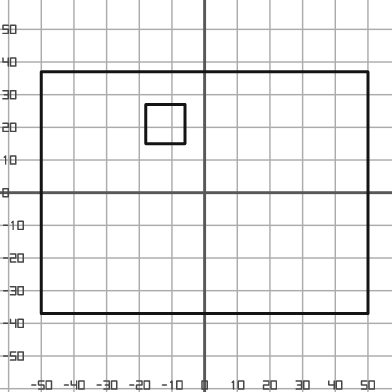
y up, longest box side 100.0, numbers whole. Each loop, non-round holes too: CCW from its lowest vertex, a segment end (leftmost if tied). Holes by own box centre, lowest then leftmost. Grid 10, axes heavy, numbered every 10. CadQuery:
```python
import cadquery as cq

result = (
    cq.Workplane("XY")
    .moveTo(-50.0, -37.0)
    .lineTo(50.0, -37.0)
    .lineTo(50.0, 37.0)
    .lineTo(-50.0, 37.0)
    .close()
    .moveTo(-18.0, 15.0)
    .lineTo(-6.0, 15.0)
    .lineTo(-6.0, 27.0)
    .lineTo(-18.0, 27.0)
    .close()
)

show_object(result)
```